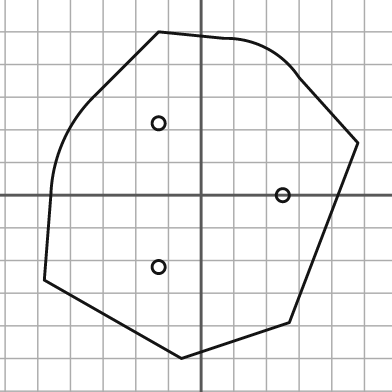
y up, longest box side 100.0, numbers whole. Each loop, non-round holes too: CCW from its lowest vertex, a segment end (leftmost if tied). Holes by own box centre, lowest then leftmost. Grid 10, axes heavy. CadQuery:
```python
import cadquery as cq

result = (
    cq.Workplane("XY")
    .moveTo(-6.0, -50.0)
    .lineTo(27.0, -39.0)
    .lineTo(48.0, 16.0)
    .lineTo(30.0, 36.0)
    .threePointArc((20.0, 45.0), (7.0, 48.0))
    .lineTo(-13.0, 50.0)
    .lineTo(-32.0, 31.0)
    .threePointArc((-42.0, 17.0), (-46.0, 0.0))
    .lineTo(-48.0, -26.0)
    .close()
    .moveTo(-13.0, -22.0)
    .circle(2.0)
    .moveTo(25.0, 0.0)
    .circle(2.0)
    .moveTo(-13.0, 22.0)
    .circle(2.0)
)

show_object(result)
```